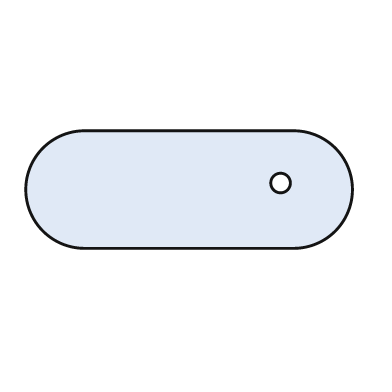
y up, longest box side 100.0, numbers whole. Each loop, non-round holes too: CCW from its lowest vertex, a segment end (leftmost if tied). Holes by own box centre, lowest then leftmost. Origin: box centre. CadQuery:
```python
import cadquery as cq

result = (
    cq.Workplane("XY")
    .moveTo(-32.0, -18.0)
    .lineTo(32.0, -18.0)
    .threePointArc((50.0, 0.0), (32.0, 18.0))
    .lineTo(-32.0, 18.0)
    .threePointArc((-50.0, 0.0), (-32.0, -18.0))
    .close()
    .moveTo(28.0, 2.0)
    .circle(3.0)
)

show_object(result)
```